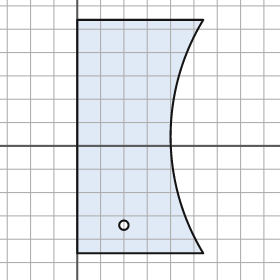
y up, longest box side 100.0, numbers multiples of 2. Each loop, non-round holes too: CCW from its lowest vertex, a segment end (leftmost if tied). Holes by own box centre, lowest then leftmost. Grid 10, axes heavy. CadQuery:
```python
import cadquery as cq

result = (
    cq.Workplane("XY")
    .moveTo(0.0, -46.0)
    .lineTo(54.0, -46.0)
    .threePointArc((40.0, 4.0), (54.0, 54.0))
    .lineTo(0.0, 54.0)
    .close()
    .moveTo(20.0, -34.0)
    .circle(2.0)
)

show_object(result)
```